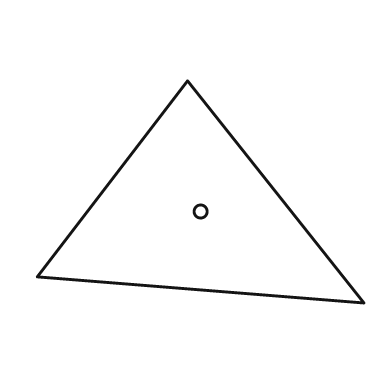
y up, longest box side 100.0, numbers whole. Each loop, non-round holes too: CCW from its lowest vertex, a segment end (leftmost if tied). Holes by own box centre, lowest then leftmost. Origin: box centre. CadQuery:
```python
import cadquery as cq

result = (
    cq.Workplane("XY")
    .moveTo(50.0, -34.0)
    .lineTo(-4.0, 34.0)
    .lineTo(-50.0, -26.0)
    .close()
    .moveTo(0.0, -6.0)
    .circle(2.0)
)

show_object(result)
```